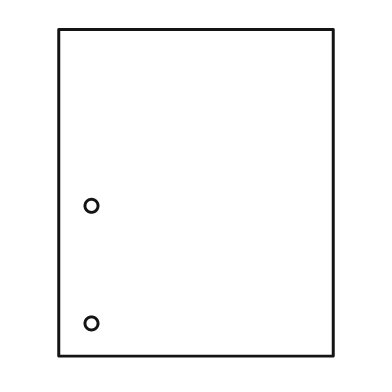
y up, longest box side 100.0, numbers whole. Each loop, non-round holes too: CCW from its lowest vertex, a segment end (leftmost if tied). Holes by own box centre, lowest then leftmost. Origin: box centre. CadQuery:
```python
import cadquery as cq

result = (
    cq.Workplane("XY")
    .moveTo(-42.0, -50.0)
    .lineTo(42.0, -50.0)
    .lineTo(42.0, 50.0)
    .lineTo(-42.0, 50.0)
    .close()
    .moveTo(-32.0, -40.0)
    .circle(2.0)
    .moveTo(-32.0, -4.0)
    .circle(2.0)
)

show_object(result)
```